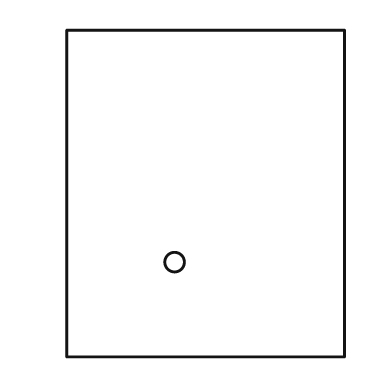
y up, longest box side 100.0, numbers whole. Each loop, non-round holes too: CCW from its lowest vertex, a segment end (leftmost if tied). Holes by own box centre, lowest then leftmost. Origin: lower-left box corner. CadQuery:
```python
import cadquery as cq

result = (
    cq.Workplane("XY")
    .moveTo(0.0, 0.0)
    .lineTo(85.0, 0.0)
    .lineTo(85.0, 100.0)
    .lineTo(0.0, 100.0)
    .close()
    .moveTo(33.0, 29.0)
    .circle(3.0)
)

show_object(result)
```